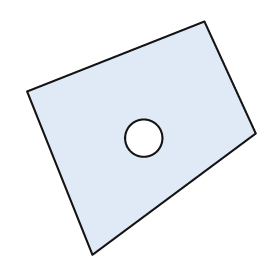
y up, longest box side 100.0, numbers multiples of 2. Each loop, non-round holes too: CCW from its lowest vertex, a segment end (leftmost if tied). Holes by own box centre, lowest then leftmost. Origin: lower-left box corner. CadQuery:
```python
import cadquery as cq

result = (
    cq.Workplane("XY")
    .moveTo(28.0, 0.0)
    .lineTo(98.0, 52.0)
    .lineTo(76.0, 100.0)
    .lineTo(0.0, 70.0)
    .close()
    .moveTo(50.0, 50.0)
    .circle(8.0)
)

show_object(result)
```